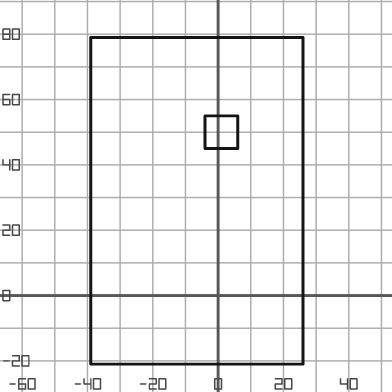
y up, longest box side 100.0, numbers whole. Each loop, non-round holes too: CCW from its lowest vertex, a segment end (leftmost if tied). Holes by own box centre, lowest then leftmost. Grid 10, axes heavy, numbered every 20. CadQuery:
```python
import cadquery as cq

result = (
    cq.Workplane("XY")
    .moveTo(-39.0, -21.0)
    .lineTo(26.0, -21.0)
    .lineTo(26.0, 79.0)
    .lineTo(-39.0, 79.0)
    .close()
    .moveTo(-4.0, 45.0)
    .lineTo(6.0, 45.0)
    .lineTo(6.0, 55.0)
    .lineTo(-4.0, 55.0)
    .close()
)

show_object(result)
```